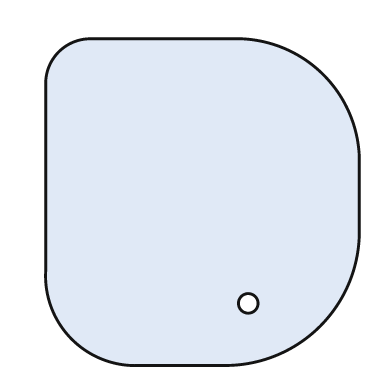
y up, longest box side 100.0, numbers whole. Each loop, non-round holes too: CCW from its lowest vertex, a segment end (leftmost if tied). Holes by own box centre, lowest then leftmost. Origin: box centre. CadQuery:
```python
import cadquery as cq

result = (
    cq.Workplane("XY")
    .moveTo(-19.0, -50.0)
    .lineTo(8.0, -50.0)
    .threePointArc((36.0, -38.0), (48.0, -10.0))
    .lineTo(48.0, 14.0)
    .threePointArc((37.0, 39.0), (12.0, 50.0))
    .lineTo(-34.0, 50.0)
    .threePointArc((-44.0, 46.0), (-48.0, 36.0))
    .lineTo(-48.0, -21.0)
    .threePointArc((-40.0, -42.0), (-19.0, -50.0))
    .close()
    .moveTo(14.0, -31.0)
    .circle(3.0)
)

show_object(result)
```